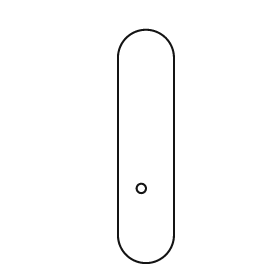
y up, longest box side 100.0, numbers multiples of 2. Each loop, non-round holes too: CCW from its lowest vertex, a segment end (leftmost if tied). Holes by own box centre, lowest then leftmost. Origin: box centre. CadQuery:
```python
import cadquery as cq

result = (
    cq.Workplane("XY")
    .moveTo(-12.0, -38.0)
    .threePointArc((0.0, -50.0), (12.0, -38.0))
    .lineTo(12.0, 38.0)
    .threePointArc((0.0, 50.0), (-12.0, 38.0))
    .close()
    .moveTo(-2.0, -18.0)
    .circle(2.0)
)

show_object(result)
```